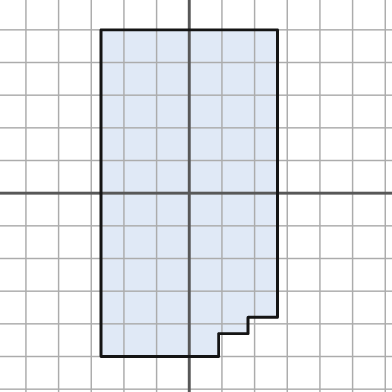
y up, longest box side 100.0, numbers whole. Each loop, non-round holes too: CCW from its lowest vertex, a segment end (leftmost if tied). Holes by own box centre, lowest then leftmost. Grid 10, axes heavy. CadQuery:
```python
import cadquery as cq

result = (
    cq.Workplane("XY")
    .moveTo(-27.0, -50.0)
    .lineTo(9.0, -50.0)
    .lineTo(9.0, -43.0)
    .lineTo(18.0, -43.0)
    .lineTo(18.0, -38.0)
    .lineTo(27.0, -38.0)
    .lineTo(27.0, 50.0)
    .lineTo(-27.0, 50.0)
    .close()
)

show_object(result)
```